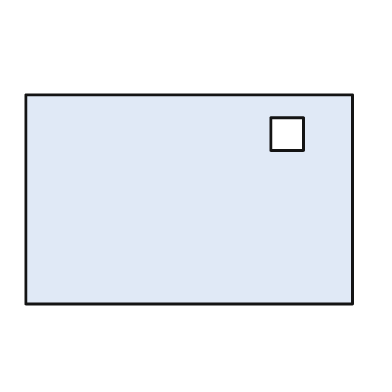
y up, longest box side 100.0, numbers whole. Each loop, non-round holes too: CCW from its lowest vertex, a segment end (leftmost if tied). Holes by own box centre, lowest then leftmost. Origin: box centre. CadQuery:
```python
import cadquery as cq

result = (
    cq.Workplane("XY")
    .moveTo(-50.0, -32.0)
    .lineTo(50.0, -32.0)
    .lineTo(50.0, 32.0)
    .lineTo(-50.0, 32.0)
    .close()
    .moveTo(25.0, 15.0)
    .lineTo(35.0, 15.0)
    .lineTo(35.0, 25.0)
    .lineTo(25.0, 25.0)
    .close()
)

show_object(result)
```